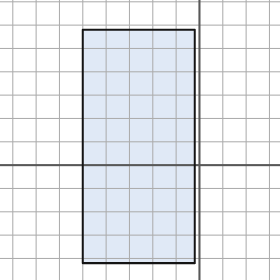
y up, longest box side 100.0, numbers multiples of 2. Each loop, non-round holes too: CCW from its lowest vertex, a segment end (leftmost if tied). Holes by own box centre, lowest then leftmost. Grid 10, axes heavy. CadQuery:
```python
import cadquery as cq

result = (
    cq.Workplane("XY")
    .moveTo(-50.0, -42.0)
    .lineTo(-2.0, -42.0)
    .lineTo(-2.0, 58.0)
    .lineTo(-50.0, 58.0)
    .close()
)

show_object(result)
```